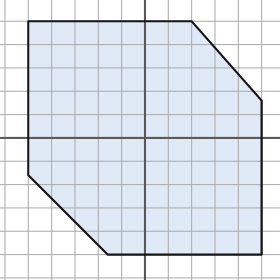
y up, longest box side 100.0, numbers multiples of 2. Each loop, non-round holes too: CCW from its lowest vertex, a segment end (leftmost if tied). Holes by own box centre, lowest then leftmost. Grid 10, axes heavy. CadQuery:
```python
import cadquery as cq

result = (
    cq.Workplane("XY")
    .moveTo(-16.0, -50.0)
    .lineTo(50.0, -50.0)
    .lineTo(50.0, 16.0)
    .lineTo(20.0, 50.0)
    .lineTo(-50.0, 50.0)
    .lineTo(-50.0, -16.0)
    .close()
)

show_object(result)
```